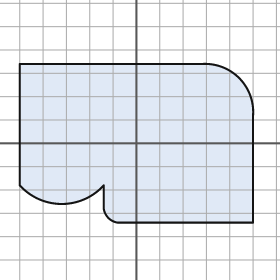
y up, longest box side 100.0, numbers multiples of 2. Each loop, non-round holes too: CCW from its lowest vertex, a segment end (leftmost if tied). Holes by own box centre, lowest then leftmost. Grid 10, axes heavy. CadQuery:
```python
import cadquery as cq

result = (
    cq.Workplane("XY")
    .moveTo(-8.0, -34.0)
    .lineTo(50.0, -34.0)
    .lineTo(50.0, 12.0)
    .threePointArc((44.0, 28.0), (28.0, 34.0))
    .lineTo(-50.0, 34.0)
    .lineTo(-50.0, -18.0)
    .threePointArc((-32.0, -26.0), (-14.0, -18.0))
    .lineTo(-14.0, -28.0)
    .threePointArc((-12.0, -32.0), (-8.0, -34.0))
    .close()
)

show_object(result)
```